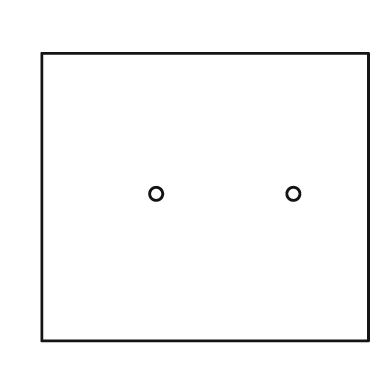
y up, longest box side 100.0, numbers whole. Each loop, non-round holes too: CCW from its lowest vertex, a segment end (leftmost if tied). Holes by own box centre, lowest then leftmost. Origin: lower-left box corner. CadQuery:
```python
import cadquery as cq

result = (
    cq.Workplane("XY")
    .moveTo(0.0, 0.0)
    .lineTo(100.0, 0.0)
    .lineTo(100.0, 88.0)
    .lineTo(0.0, 88.0)
    .close()
    .moveTo(35.0, 45.0)
    .circle(2.0)
    .moveTo(77.0, 45.0)
    .circle(2.0)
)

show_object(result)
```